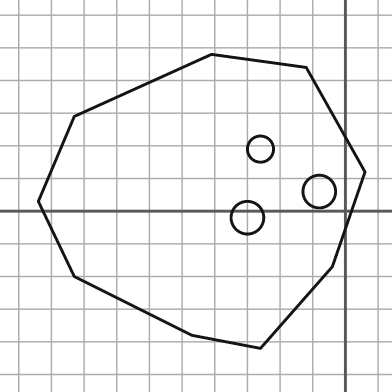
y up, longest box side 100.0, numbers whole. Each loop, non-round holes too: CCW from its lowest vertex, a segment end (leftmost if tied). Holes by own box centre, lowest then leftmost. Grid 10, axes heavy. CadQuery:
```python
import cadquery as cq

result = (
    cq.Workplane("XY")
    .moveTo(-26.0, -42.0)
    .lineTo(-4.0, -17.0)
    .lineTo(6.0, 12.0)
    .lineTo(-12.0, 44.0)
    .lineTo(-41.0, 48.0)
    .lineTo(-83.0, 29.0)
    .lineTo(-94.0, 3.0)
    .lineTo(-83.0, -20.0)
    .lineTo(-47.0, -38.0)
    .close()
    .moveTo(-30.0, -2.0)
    .circle(5.0)
    .moveTo(-8.0, 6.0)
    .circle(5.0)
    .moveTo(-26.0, 19.0)
    .circle(4.0)
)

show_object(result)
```